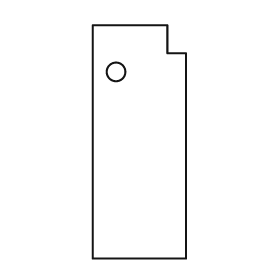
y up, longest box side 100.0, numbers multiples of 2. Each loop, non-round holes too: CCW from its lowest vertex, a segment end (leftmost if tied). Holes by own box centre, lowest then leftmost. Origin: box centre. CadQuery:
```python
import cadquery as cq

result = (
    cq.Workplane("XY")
    .moveTo(-20.0, -50.0)
    .lineTo(20.0, -50.0)
    .lineTo(20.0, 38.0)
    .lineTo(12.0, 38.0)
    .lineTo(12.0, 50.0)
    .lineTo(-20.0, 50.0)
    .close()
    .moveTo(-10.0, 30.0)
    .circle(4.0)
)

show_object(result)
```